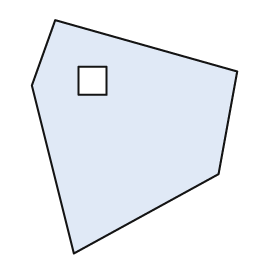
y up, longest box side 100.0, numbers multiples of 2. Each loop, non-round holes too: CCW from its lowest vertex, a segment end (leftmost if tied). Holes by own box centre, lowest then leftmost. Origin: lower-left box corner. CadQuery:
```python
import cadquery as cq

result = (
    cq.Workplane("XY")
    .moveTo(18.0, 0.0)
    .lineTo(80.0, 34.0)
    .lineTo(88.0, 78.0)
    .lineTo(10.0, 100.0)
    .lineTo(0.0, 72.0)
    .close()
    .moveTo(20.0, 68.0)
    .lineTo(32.0, 68.0)
    .lineTo(32.0, 80.0)
    .lineTo(20.0, 80.0)
    .close()
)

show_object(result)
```